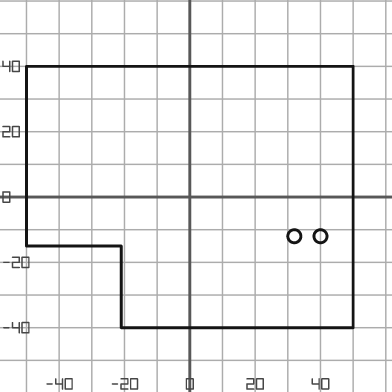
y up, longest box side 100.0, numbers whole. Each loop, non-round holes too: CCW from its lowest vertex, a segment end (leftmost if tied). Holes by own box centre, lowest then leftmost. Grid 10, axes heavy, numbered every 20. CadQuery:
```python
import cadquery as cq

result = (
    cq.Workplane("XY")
    .moveTo(-21.0, -40.0)
    .lineTo(50.0, -40.0)
    .lineTo(50.0, 40.0)
    .lineTo(-50.0, 40.0)
    .lineTo(-50.0, -15.0)
    .lineTo(-21.0, -15.0)
    .close()
    .moveTo(32.0, -12.0)
    .circle(2.0)
    .moveTo(40.0, -12.0)
    .circle(2.0)
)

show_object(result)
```